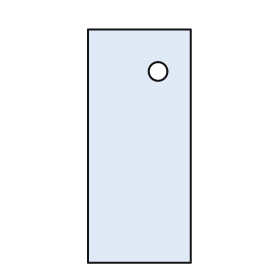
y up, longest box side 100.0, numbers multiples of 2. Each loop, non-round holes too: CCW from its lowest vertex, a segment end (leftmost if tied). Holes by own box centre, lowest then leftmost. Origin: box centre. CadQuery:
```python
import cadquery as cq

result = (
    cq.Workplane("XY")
    .moveTo(-22.0, -50.0)
    .lineTo(22.0, -50.0)
    .lineTo(22.0, 50.0)
    .lineTo(-22.0, 50.0)
    .close()
    .moveTo(8.0, 32.0)
    .circle(4.0)
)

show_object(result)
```